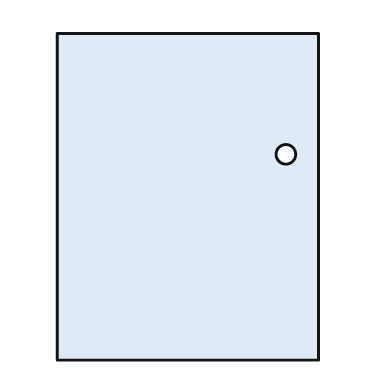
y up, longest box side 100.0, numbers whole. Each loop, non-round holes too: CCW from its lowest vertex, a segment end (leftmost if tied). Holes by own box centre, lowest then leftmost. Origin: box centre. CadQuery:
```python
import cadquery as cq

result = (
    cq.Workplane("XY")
    .moveTo(-40.0, -50.0)
    .lineTo(40.0, -50.0)
    .lineTo(40.0, 50.0)
    .lineTo(-40.0, 50.0)
    .close()
    .moveTo(30.0, 13.0)
    .circle(3.0)
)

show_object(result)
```